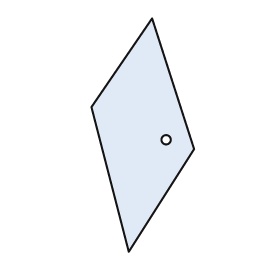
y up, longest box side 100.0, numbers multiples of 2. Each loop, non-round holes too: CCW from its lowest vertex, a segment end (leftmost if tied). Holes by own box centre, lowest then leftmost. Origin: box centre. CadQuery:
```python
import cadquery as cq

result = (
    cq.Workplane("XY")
    .moveTo(-6.0, -50.0)
    .lineTo(22.0, -6.0)
    .lineTo(4.0, 50.0)
    .lineTo(-22.0, 12.0)
    .close()
    .moveTo(10.0, -2.0)
    .circle(2.0)
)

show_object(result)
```